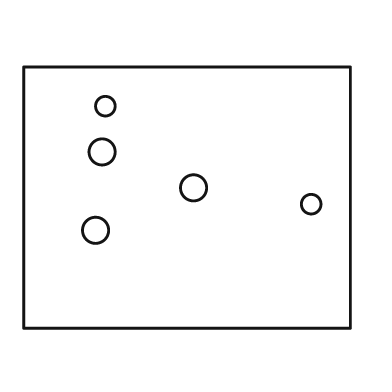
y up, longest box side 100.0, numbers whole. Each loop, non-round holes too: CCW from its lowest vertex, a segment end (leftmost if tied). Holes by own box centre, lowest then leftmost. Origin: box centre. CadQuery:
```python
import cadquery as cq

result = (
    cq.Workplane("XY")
    .moveTo(-50.0, -40.0)
    .lineTo(50.0, -40.0)
    .lineTo(50.0, 40.0)
    .lineTo(-50.0, 40.0)
    .close()
    .moveTo(-28.0, -10.0)
    .circle(4.0)
    .moveTo(38.0, -2.0)
    .circle(3.0)
    .moveTo(2.0, 3.0)
    .circle(4.0)
    .moveTo(-26.0, 14.0)
    .circle(4.0)
    .moveTo(-25.0, 28.0)
    .circle(3.0)
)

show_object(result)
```